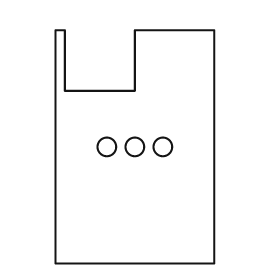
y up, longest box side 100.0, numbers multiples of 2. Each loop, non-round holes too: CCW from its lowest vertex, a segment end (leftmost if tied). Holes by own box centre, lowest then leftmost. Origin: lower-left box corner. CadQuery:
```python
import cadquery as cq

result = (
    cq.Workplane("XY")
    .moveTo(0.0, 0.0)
    .lineTo(68.0, 0.0)
    .lineTo(68.0, 100.0)
    .lineTo(34.0, 100.0)
    .lineTo(34.0, 74.0)
    .lineTo(4.0, 74.0)
    .lineTo(4.0, 100.0)
    .lineTo(0.0, 100.0)
    .close()
    .moveTo(22.0, 50.0)
    .circle(4.0)
    .moveTo(34.0, 50.0)
    .circle(4.0)
    .moveTo(46.0, 50.0)
    .circle(4.0)
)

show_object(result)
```